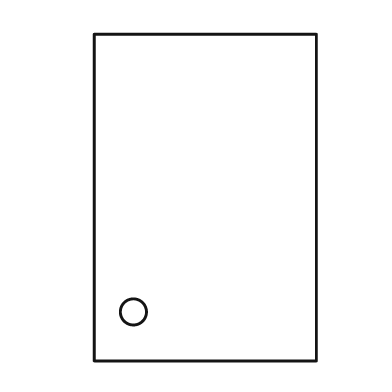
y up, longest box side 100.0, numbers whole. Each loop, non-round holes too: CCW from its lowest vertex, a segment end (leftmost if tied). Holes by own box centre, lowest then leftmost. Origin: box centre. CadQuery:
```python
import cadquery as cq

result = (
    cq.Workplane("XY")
    .moveTo(-34.0, -50.0)
    .lineTo(34.0, -50.0)
    .lineTo(34.0, 50.0)
    .lineTo(-34.0, 50.0)
    .close()
    .moveTo(-22.0, -35.0)
    .circle(4.0)
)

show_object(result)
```